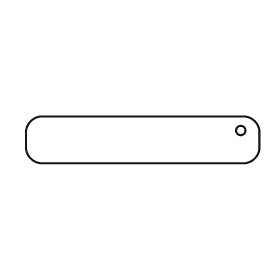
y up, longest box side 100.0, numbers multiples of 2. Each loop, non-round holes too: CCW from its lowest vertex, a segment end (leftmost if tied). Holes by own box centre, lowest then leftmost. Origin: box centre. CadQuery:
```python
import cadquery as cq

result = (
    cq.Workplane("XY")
    .moveTo(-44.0, -10.0)
    .lineTo(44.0, -10.0)
    .threePointArc((48.0, -8.0), (50.0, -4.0))
    .lineTo(50.0, 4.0)
    .threePointArc((48.0, 8.0), (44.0, 10.0))
    .lineTo(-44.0, 10.0)
    .threePointArc((-48.0, 8.0), (-50.0, 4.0))
    .lineTo(-50.0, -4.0)
    .threePointArc((-48.0, -8.0), (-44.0, -10.0))
    .close()
    .moveTo(42.0, 4.0)
    .circle(2.0)
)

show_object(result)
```